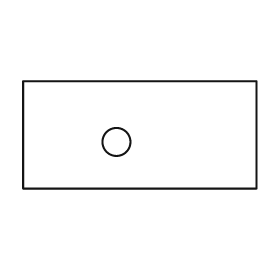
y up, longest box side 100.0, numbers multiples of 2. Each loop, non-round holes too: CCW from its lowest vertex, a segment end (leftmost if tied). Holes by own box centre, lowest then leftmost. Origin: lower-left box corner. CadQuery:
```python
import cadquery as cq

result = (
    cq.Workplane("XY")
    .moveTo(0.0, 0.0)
    .lineTo(100.0, 0.0)
    .lineTo(100.0, 46.0)
    .lineTo(0.0, 46.0)
    .close()
    .moveTo(40.0, 20.0)
    .circle(6.0)
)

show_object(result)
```